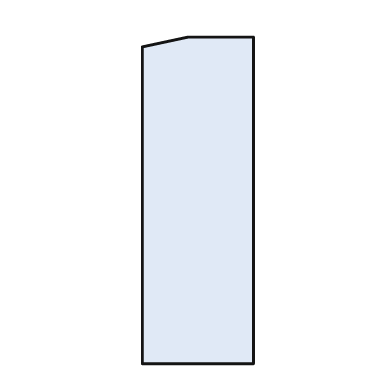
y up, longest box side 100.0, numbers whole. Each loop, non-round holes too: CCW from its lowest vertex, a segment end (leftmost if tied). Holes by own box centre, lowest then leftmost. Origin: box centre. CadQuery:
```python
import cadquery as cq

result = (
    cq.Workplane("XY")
    .moveTo(-17.0, -50.0)
    .lineTo(17.0, -50.0)
    .lineTo(17.0, 50.0)
    .lineTo(-3.0, 50.0)
    .lineTo(-17.0, 47.0)
    .close()
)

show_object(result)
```